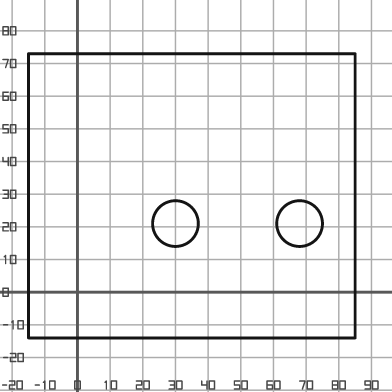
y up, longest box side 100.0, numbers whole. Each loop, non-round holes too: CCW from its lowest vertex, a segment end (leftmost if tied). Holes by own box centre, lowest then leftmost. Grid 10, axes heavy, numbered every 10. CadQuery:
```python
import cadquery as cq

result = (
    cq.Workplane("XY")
    .moveTo(-15.0, -14.0)
    .lineTo(85.0, -14.0)
    .lineTo(85.0, 73.0)
    .lineTo(-15.0, 73.0)
    .close()
    .moveTo(30.0, 21.0)
    .circle(7.0)
    .moveTo(68.0, 21.0)
    .circle(7.0)
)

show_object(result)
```